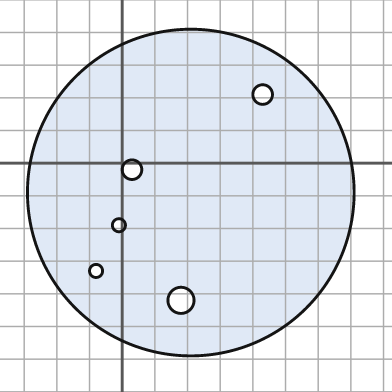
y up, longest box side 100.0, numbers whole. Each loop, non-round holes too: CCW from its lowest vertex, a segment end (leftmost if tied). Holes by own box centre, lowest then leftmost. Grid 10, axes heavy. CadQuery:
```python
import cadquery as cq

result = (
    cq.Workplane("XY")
    .moveTo(21.0, -9.0)
    .circle(50.0)
    .moveTo(18.0, -42.0)
    .circle(4.0)
    .moveTo(-8.0, -33.0)
    .circle(2.0)
    .moveTo(-1.0, -19.0)
    .circle(2.0)
    .moveTo(3.0, -2.0)
    .circle(3.0)
    .moveTo(43.0, 21.0)
    .circle(3.0)
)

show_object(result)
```